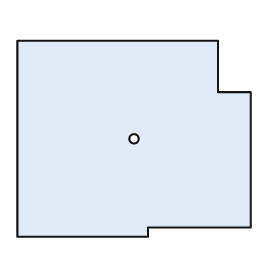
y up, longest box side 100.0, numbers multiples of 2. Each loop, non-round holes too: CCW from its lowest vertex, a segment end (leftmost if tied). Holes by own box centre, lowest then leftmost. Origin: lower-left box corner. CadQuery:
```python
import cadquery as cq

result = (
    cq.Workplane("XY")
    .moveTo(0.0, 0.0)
    .lineTo(56.0, 0.0)
    .lineTo(56.0, 4.0)
    .lineTo(100.0, 4.0)
    .lineTo(100.0, 62.0)
    .lineTo(86.0, 62.0)
    .lineTo(86.0, 84.0)
    .lineTo(0.0, 84.0)
    .close()
    .moveTo(50.0, 42.0)
    .circle(2.0)
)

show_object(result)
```